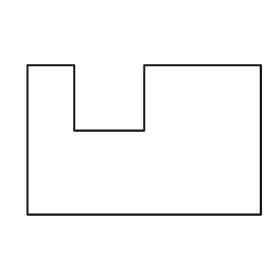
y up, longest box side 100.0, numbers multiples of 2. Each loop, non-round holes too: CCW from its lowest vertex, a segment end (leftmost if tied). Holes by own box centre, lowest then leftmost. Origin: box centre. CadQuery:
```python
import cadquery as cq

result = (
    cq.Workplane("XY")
    .moveTo(-50.0, -32.0)
    .lineTo(50.0, -32.0)
    .lineTo(50.0, 32.0)
    .lineTo(0.0, 32.0)
    .lineTo(0.0, 4.0)
    .lineTo(-30.0, 4.0)
    .lineTo(-30.0, 32.0)
    .lineTo(-50.0, 32.0)
    .close()
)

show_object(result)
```